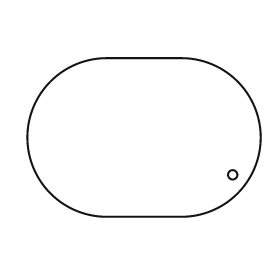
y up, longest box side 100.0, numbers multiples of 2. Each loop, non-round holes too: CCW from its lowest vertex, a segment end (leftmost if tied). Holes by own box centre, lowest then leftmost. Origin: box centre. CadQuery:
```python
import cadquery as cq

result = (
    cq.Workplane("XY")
    .moveTo(-16.0, -34.0)
    .lineTo(16.0, -34.0)
    .threePointArc((50.0, 0.0), (16.0, 34.0))
    .lineTo(-16.0, 34.0)
    .threePointArc((-50.0, 0.0), (-16.0, -34.0))
    .close()
    .moveTo(38.0, -16.0)
    .circle(2.0)
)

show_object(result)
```